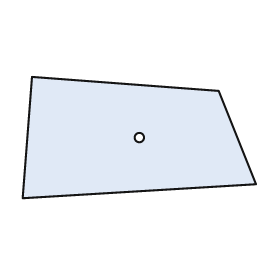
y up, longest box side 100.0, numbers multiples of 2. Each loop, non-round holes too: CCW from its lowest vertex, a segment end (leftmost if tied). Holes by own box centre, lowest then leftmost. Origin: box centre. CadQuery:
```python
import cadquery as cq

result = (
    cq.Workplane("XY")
    .moveTo(-50.0, -26.0)
    .lineTo(50.0, -20.0)
    .lineTo(34.0, 20.0)
    .lineTo(-46.0, 26.0)
    .close()
    .moveTo(0.0, 0.0)
    .circle(2.0)
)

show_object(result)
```